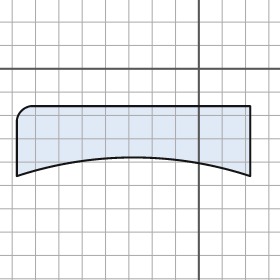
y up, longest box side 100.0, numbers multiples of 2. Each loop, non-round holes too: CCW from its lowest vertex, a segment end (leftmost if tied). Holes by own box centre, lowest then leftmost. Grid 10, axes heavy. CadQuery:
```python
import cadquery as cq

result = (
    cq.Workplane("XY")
    .moveTo(-78.0, -46.0)
    .threePointArc((-28.0, -38.0), (22.0, -46.0))
    .lineTo(22.0, -16.0)
    .lineTo(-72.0, -16.0)
    .threePointArc((-76.0, -18.0), (-78.0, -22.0))
    .close()
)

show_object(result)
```